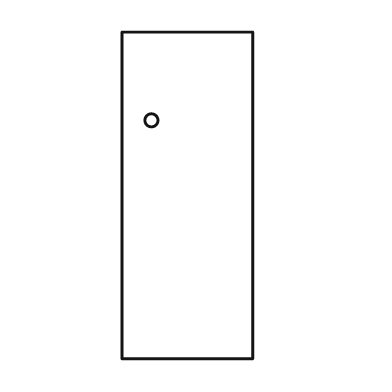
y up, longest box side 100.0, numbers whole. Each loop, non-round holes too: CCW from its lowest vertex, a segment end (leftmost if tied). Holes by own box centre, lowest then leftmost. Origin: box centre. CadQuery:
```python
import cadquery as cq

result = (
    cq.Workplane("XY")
    .moveTo(-20.0, -50.0)
    .lineTo(20.0, -50.0)
    .lineTo(20.0, 50.0)
    .lineTo(-20.0, 50.0)
    .close()
    .moveTo(-11.0, 23.0)
    .circle(2.0)
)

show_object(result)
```